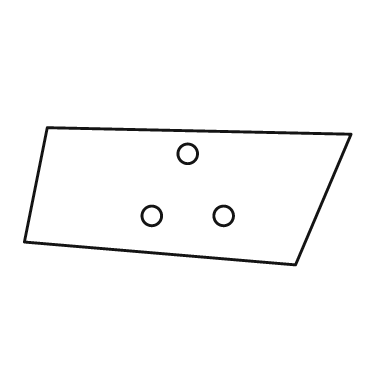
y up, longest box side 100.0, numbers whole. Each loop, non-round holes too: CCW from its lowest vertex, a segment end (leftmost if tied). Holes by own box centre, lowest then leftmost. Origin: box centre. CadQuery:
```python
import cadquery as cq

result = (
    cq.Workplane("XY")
    .moveTo(33.0, -21.0)
    .lineTo(50.0, 19.0)
    .lineTo(-43.0, 21.0)
    .lineTo(-50.0, -14.0)
    .close()
    .moveTo(-11.0, -6.0)
    .circle(3.0)
    .moveTo(11.0, -6.0)
    .circle(3.0)
    .moveTo(0.0, 13.0)
    .circle(3.0)
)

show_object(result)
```